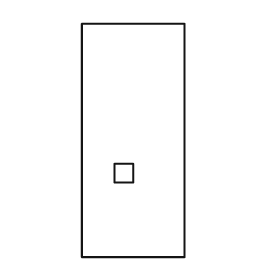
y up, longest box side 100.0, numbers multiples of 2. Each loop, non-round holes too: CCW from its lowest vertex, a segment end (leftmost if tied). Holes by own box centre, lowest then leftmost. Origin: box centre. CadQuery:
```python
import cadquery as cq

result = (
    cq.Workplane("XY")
    .moveTo(-22.0, -50.0)
    .lineTo(22.0, -50.0)
    .lineTo(22.0, 50.0)
    .lineTo(-22.0, 50.0)
    .close()
    .moveTo(-8.0, -18.0)
    .lineTo(0.0, -18.0)
    .lineTo(0.0, -10.0)
    .lineTo(-8.0, -10.0)
    .close()
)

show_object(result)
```